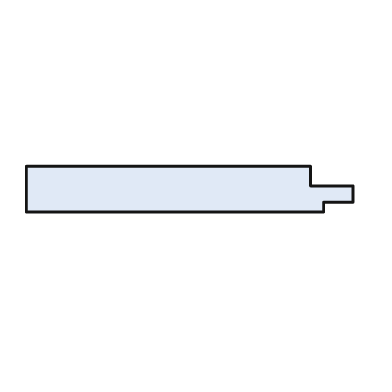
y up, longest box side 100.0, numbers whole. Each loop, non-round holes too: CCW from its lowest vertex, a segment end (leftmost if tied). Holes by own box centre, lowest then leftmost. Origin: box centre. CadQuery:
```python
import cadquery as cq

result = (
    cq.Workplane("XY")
    .moveTo(-50.0, -7.0)
    .lineTo(41.0, -7.0)
    .lineTo(41.0, -4.0)
    .lineTo(50.0, -4.0)
    .lineTo(50.0, 1.0)
    .lineTo(37.0, 1.0)
    .lineTo(37.0, 7.0)
    .lineTo(-50.0, 7.0)
    .close()
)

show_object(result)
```